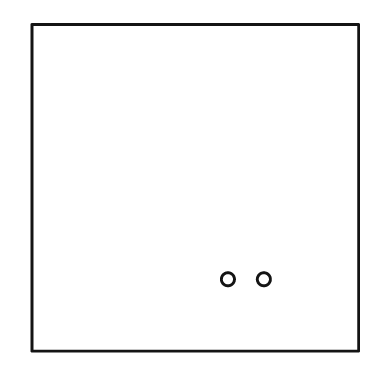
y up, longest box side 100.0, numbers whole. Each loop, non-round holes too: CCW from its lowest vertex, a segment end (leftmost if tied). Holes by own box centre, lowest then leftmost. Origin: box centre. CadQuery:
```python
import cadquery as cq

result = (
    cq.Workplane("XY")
    .moveTo(-50.0, -50.0)
    .lineTo(50.0, -50.0)
    .lineTo(50.0, 50.0)
    .lineTo(-50.0, 50.0)
    .close()
    .moveTo(10.0, -28.0)
    .circle(2.0)
    .moveTo(21.0, -28.0)
    .circle(2.0)
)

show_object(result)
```